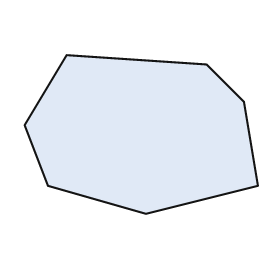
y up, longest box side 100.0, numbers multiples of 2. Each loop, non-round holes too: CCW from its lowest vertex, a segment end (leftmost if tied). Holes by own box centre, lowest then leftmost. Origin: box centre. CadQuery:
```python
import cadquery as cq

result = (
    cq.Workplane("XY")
    .moveTo(2.0, -34.0)
    .lineTo(50.0, -22.0)
    .lineTo(44.0, 14.0)
    .lineTo(28.0, 30.0)
    .lineTo(-32.0, 34.0)
    .lineTo(-50.0, 4.0)
    .lineTo(-40.0, -22.0)
    .close()
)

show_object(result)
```